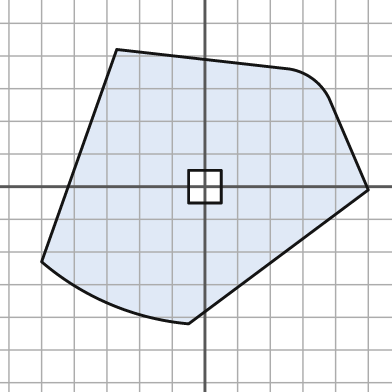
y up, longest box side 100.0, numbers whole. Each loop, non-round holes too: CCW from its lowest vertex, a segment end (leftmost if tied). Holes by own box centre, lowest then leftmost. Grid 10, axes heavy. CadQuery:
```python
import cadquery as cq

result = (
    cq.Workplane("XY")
    .moveTo(-5.0, -42.0)
    .lineTo(50.0, -1.0)
    .lineTo(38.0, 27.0)
    .threePointArc((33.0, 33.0), (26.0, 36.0))
    .lineTo(-27.0, 42.0)
    .lineTo(-50.0, -23.0)
    .threePointArc((-29.0, -36.0), (-5.0, -42.0))
    .close()
    .moveTo(-5.0, -5.0)
    .lineTo(5.0, -5.0)
    .lineTo(5.0, 5.0)
    .lineTo(-5.0, 5.0)
    .close()
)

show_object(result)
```